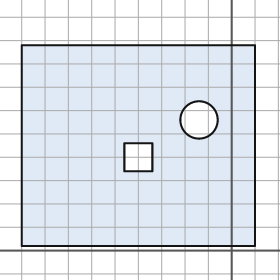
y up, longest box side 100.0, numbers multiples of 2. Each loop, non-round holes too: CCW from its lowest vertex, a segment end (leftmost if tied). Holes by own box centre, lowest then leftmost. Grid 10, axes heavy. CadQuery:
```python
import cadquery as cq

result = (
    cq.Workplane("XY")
    .moveTo(-90.0, 2.0)
    .lineTo(10.0, 2.0)
    .lineTo(10.0, 88.0)
    .lineTo(-90.0, 88.0)
    .close()
    .moveTo(-46.0, 34.0)
    .lineTo(-34.0, 34.0)
    .lineTo(-34.0, 46.0)
    .lineTo(-46.0, 46.0)
    .close()
    .moveTo(-14.0, 56.0)
    .circle(8.0)
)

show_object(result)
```